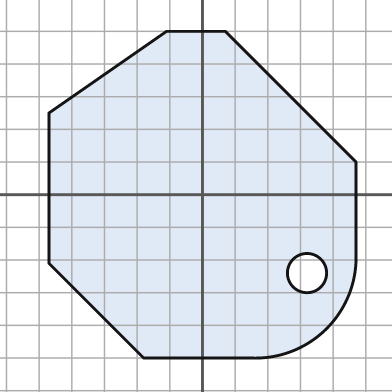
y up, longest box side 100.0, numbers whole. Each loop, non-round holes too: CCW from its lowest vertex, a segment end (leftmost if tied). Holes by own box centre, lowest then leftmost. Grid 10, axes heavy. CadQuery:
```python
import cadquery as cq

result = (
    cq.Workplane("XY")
    .moveTo(-18.0, -50.0)
    .lineTo(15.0, -50.0)
    .threePointArc((38.0, -41.0), (47.0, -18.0))
    .lineTo(47.0, 10.0)
    .lineTo(7.0, 50.0)
    .lineTo(-11.0, 50.0)
    .lineTo(-47.0, 25.0)
    .lineTo(-47.0, -21.0)
    .close()
    .moveTo(32.0, -24.0)
    .circle(6.0)
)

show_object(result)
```